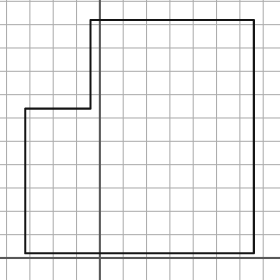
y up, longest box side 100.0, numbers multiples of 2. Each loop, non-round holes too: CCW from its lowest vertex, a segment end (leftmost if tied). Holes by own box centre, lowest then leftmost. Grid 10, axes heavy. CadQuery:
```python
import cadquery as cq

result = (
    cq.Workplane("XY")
    .moveTo(-32.0, 2.0)
    .lineTo(66.0, 2.0)
    .lineTo(66.0, 102.0)
    .lineTo(-4.0, 102.0)
    .lineTo(-4.0, 64.0)
    .lineTo(-32.0, 64.0)
    .close()
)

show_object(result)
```